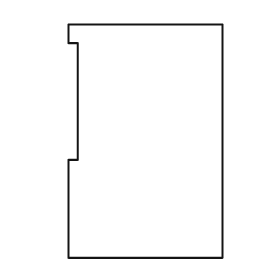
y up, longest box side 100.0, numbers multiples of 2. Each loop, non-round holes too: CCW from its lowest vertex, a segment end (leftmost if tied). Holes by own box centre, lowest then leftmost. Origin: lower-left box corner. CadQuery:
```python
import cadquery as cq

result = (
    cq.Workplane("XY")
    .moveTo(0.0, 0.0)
    .lineTo(66.0, 0.0)
    .lineTo(66.0, 100.0)
    .lineTo(0.0, 100.0)
    .lineTo(0.0, 92.0)
    .lineTo(4.0, 92.0)
    .lineTo(4.0, 42.0)
    .lineTo(0.0, 42.0)
    .close()
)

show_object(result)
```